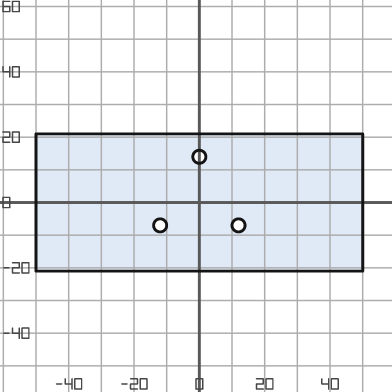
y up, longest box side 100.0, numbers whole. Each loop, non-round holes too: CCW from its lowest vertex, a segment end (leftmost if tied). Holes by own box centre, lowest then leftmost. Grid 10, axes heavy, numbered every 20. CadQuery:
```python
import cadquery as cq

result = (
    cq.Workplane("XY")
    .moveTo(-50.0, -21.0)
    .lineTo(50.0, -21.0)
    .lineTo(50.0, 21.0)
    .lineTo(-50.0, 21.0)
    .close()
    .moveTo(-12.0, -7.0)
    .circle(2.0)
    .moveTo(12.0, -7.0)
    .circle(2.0)
    .moveTo(0.0, 14.0)
    .circle(2.0)
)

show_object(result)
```